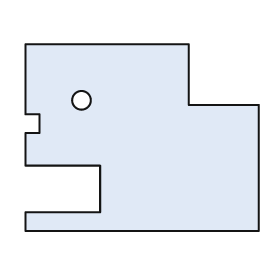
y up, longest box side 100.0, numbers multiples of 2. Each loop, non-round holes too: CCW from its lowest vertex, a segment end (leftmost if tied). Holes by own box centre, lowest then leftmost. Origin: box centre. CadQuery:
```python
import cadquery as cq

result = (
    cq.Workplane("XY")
    .moveTo(-50.0, -40.0)
    .lineTo(50.0, -40.0)
    .lineTo(50.0, 14.0)
    .lineTo(20.0, 14.0)
    .lineTo(20.0, 40.0)
    .lineTo(-50.0, 40.0)
    .lineTo(-50.0, 10.0)
    .lineTo(-44.0, 10.0)
    .lineTo(-44.0, 2.0)
    .lineTo(-50.0, 2.0)
    .lineTo(-50.0, -12.0)
    .lineTo(-18.0, -12.0)
    .lineTo(-18.0, -32.0)
    .lineTo(-50.0, -32.0)
    .close()
    .moveTo(-26.0, 16.0)
    .circle(4.0)
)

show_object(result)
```